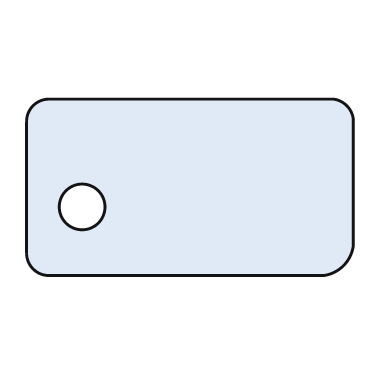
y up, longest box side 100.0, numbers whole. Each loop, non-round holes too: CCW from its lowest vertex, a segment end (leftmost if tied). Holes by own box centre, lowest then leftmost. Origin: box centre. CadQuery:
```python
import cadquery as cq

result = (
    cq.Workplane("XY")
    .moveTo(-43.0, -27.0)
    .lineTo(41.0, -27.0)
    .threePointArc((47.0, -24.0), (50.0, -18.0))
    .lineTo(50.0, 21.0)
    .threePointArc((48.0, 25.0), (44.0, 27.0))
    .lineTo(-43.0, 27.0)
    .threePointArc((-48.0, 25.0), (-50.0, 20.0))
    .lineTo(-50.0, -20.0)
    .threePointArc((-48.0, -25.0), (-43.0, -27.0))
    .close()
    .moveTo(-33.0, -6.0)
    .circle(7.0)
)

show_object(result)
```